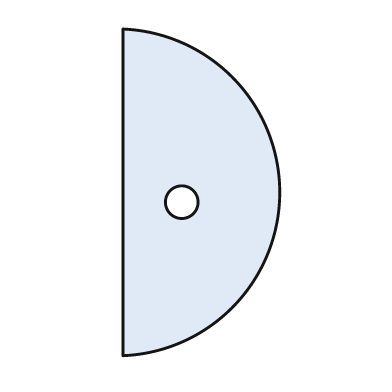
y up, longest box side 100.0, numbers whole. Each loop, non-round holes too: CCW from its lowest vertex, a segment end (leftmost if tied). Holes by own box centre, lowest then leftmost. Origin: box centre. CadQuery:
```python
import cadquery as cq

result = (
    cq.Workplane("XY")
    .moveTo(-24.0, -50.0)
    .threePointArc((24.0, 0.0), (-24.0, 50.0))
    .close()
    .moveTo(-6.0, -3.0)
    .circle(5.0)
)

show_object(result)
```